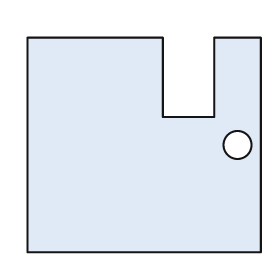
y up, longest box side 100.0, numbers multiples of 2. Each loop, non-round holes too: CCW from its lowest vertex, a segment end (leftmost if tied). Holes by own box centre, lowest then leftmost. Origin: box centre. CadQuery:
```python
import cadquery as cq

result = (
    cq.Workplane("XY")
    .moveTo(-50.0, -46.0)
    .lineTo(50.0, -46.0)
    .lineTo(50.0, 46.0)
    .lineTo(30.0, 46.0)
    .lineTo(30.0, 12.0)
    .lineTo(8.0, 12.0)
    .lineTo(8.0, 46.0)
    .lineTo(-50.0, 46.0)
    .close()
    .moveTo(40.0, 0.0)
    .circle(6.0)
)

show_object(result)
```